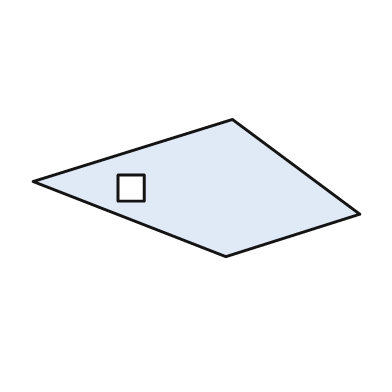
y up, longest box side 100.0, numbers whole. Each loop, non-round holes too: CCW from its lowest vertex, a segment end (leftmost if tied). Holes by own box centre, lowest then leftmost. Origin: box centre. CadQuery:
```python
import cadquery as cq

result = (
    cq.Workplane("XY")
    .moveTo(9.0, -21.0)
    .lineTo(50.0, -8.0)
    .lineTo(11.0, 21.0)
    .lineTo(-50.0, 2.0)
    .close()
    .moveTo(-24.0, -4.0)
    .lineTo(-16.0, -4.0)
    .lineTo(-16.0, 4.0)
    .lineTo(-24.0, 4.0)
    .close()
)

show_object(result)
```